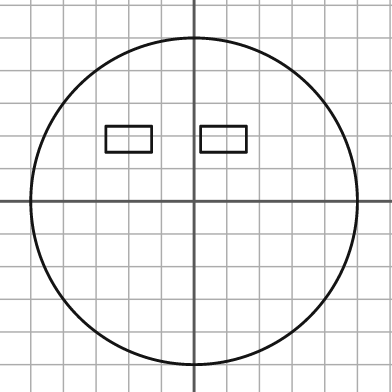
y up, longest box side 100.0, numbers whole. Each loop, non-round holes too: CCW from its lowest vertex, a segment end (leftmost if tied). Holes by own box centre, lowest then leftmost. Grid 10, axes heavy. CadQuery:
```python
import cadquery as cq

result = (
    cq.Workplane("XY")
    .moveTo(0.0, 0.0)
    .circle(50.0)
    .moveTo(-27.0, 15.0)
    .lineTo(-13.0, 15.0)
    .lineTo(-13.0, 23.0)
    .lineTo(-27.0, 23.0)
    .close()
    .moveTo(2.0, 15.0)
    .lineTo(16.0, 15.0)
    .lineTo(16.0, 23.0)
    .lineTo(2.0, 23.0)
    .close()
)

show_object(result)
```